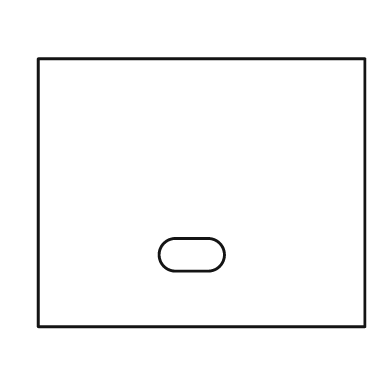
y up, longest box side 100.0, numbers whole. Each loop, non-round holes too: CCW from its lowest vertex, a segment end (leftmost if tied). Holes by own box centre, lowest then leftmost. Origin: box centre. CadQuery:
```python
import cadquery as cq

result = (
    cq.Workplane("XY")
    .moveTo(-50.0, -41.0)
    .lineTo(50.0, -41.0)
    .lineTo(50.0, 41.0)
    .lineTo(-50.0, 41.0)
    .close()
    .moveTo(-8.0, -24.0)
    .lineTo(2.0, -24.0)
    .threePointArc((7.0, -19.0), (2.0, -14.0))
    .lineTo(-8.0, -14.0)
    .threePointArc((-13.0, -19.0), (-8.0, -24.0))
    .close()
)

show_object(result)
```